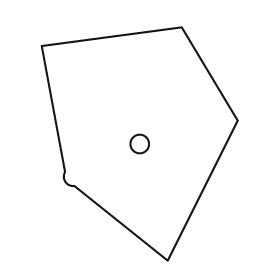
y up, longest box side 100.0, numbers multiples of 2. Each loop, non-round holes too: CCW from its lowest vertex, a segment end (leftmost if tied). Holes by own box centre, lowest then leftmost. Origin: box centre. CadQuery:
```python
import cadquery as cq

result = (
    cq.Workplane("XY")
    .moveTo(12.0, -50.0)
    .lineTo(42.0, 10.0)
    .lineTo(18.0, 50.0)
    .lineTo(-42.0, 42.0)
    .lineTo(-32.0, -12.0)
    .threePointArc((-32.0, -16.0), (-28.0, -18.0))
    .close()
    .moveTo(0.0, 0.0)
    .circle(4.0)
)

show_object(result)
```